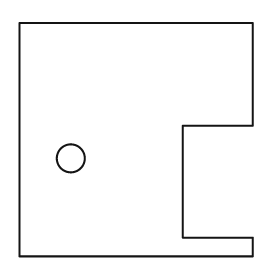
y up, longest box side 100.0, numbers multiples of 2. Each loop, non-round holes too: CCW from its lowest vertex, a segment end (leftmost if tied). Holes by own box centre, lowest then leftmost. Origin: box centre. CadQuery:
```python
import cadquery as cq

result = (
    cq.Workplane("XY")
    .moveTo(-50.0, -50.0)
    .lineTo(50.0, -50.0)
    .lineTo(50.0, -42.0)
    .lineTo(20.0, -42.0)
    .lineTo(20.0, 6.0)
    .lineTo(50.0, 6.0)
    .lineTo(50.0, 50.0)
    .lineTo(-50.0, 50.0)
    .close()
    .moveTo(-28.0, -8.0)
    .circle(6.0)
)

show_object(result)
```